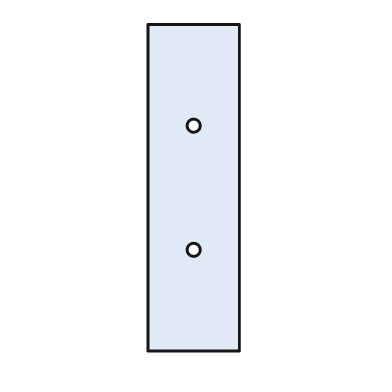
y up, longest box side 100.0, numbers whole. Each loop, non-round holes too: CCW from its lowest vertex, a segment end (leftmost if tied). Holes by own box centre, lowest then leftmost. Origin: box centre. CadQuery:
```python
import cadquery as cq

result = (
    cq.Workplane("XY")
    .moveTo(-14.0, -50.0)
    .lineTo(14.0, -50.0)
    .lineTo(14.0, 50.0)
    .lineTo(-14.0, 50.0)
    .close()
    .moveTo(0.0, -19.0)
    .circle(2.0)
    .moveTo(0.0, 19.0)
    .circle(2.0)
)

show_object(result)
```